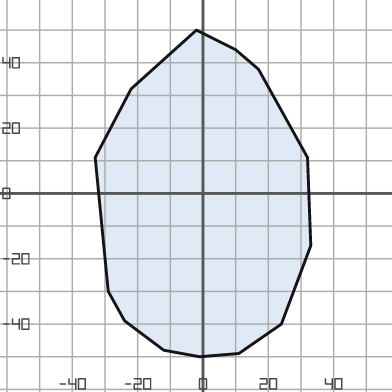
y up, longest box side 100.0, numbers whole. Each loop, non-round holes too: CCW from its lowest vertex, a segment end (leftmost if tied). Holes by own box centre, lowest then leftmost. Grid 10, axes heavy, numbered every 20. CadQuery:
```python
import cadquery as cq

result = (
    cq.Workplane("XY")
    .moveTo(-1.0, -50.0)
    .lineTo(11.0, -49.0)
    .lineTo(24.0, -40.0)
    .lineTo(33.0, -16.0)
    .lineTo(32.0, 11.0)
    .lineTo(17.0, 38.0)
    .lineTo(10.0, 44.0)
    .lineTo(-2.0, 50.0)
    .lineTo(-22.0, 32.0)
    .lineTo(-33.0, 11.0)
    .lineTo(-29.0, -30.0)
    .lineTo(-24.0, -39.0)
    .lineTo(-12.0, -48.0)
    .close()
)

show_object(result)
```